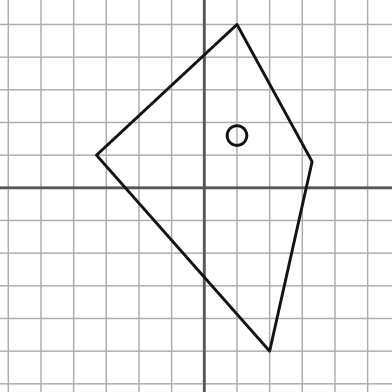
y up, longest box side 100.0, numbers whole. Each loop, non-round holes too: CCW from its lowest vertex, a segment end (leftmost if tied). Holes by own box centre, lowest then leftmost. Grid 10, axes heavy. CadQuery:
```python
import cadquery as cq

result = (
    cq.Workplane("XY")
    .moveTo(20.0, -50.0)
    .lineTo(33.0, 8.0)
    .lineTo(10.0, 50.0)
    .lineTo(-33.0, 10.0)
    .close()
    .moveTo(10.0, 16.0)
    .circle(3.0)
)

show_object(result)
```